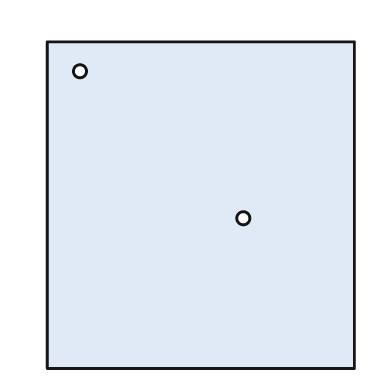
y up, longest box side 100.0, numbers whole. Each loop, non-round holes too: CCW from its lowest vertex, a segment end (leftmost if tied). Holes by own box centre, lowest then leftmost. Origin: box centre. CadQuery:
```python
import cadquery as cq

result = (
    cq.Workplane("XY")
    .moveTo(-47.0, -50.0)
    .lineTo(47.0, -50.0)
    .lineTo(47.0, 50.0)
    .lineTo(-47.0, 50.0)
    .close()
    .moveTo(13.0, -4.0)
    .circle(2.0)
    .moveTo(-37.0, 41.0)
    .circle(2.0)
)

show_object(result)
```